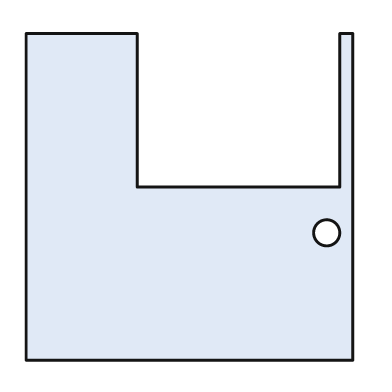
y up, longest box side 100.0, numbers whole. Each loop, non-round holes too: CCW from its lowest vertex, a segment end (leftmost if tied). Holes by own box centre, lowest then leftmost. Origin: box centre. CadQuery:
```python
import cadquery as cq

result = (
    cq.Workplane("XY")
    .moveTo(-50.0, -50.0)
    .lineTo(50.0, -50.0)
    .lineTo(50.0, 50.0)
    .lineTo(46.0, 50.0)
    .lineTo(46.0, 3.0)
    .lineTo(-16.0, 3.0)
    .lineTo(-16.0, 50.0)
    .lineTo(-50.0, 50.0)
    .close()
    .moveTo(42.0, -11.0)
    .circle(4.0)
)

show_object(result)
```